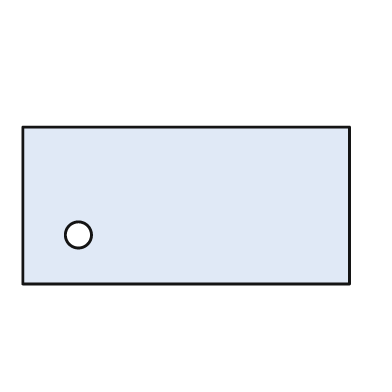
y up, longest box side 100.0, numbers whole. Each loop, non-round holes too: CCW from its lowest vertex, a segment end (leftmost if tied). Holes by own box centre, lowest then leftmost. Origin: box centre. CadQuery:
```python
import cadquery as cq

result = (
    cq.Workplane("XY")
    .moveTo(-50.0, -24.0)
    .lineTo(50.0, -24.0)
    .lineTo(50.0, 24.0)
    .lineTo(-50.0, 24.0)
    .close()
    .moveTo(-33.0, -9.0)
    .circle(4.0)
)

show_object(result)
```